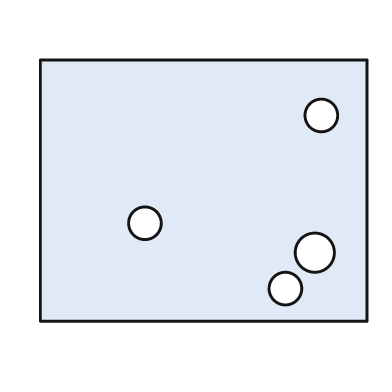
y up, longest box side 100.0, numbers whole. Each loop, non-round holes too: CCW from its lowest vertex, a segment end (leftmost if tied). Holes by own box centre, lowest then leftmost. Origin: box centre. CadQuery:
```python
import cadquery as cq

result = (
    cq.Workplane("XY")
    .moveTo(-50.0, -40.0)
    .lineTo(50.0, -40.0)
    .lineTo(50.0, 40.0)
    .lineTo(-50.0, 40.0)
    .close()
    .moveTo(25.0, -30.0)
    .circle(5.0)
    .moveTo(34.0, -19.0)
    .circle(6.0)
    .moveTo(-18.0, -10.0)
    .circle(5.0)
    .moveTo(36.0, 23.0)
    .circle(5.0)
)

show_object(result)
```